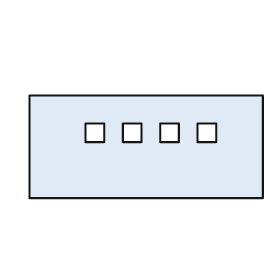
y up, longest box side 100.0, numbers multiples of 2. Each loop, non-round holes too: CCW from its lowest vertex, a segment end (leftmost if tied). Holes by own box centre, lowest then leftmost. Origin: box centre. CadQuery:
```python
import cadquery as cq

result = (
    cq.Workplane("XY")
    .moveTo(-50.0, -22.0)
    .lineTo(50.0, -22.0)
    .lineTo(50.0, 22.0)
    .lineTo(-50.0, 22.0)
    .close()
    .moveTo(-26.0, 2.0)
    .lineTo(-18.0, 2.0)
    .lineTo(-18.0, 10.0)
    .lineTo(-26.0, 10.0)
    .close()
    .moveTo(-10.0, 2.0)
    .lineTo(-2.0, 2.0)
    .lineTo(-2.0, 10.0)
    .lineTo(-10.0, 10.0)
    .close()
    .moveTo(6.0, 2.0)
    .lineTo(14.0, 2.0)
    .lineTo(14.0, 10.0)
    .lineTo(6.0, 10.0)
    .close()
    .moveTo(22.0, 2.0)
    .lineTo(30.0, 2.0)
    .lineTo(30.0, 10.0)
    .lineTo(22.0, 10.0)
    .close()
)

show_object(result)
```